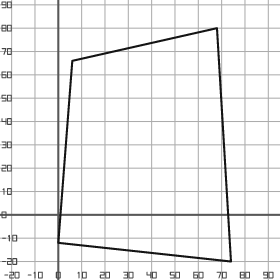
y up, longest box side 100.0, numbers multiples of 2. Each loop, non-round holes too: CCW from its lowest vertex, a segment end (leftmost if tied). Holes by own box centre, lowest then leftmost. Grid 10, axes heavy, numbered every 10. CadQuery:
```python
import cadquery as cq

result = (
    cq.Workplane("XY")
    .moveTo(74.0, -20.0)
    .lineTo(68.0, 80.0)
    .lineTo(6.0, 66.0)
    .lineTo(0.0, -12.0)
    .close()
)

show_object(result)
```